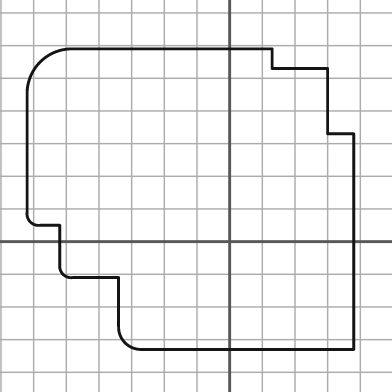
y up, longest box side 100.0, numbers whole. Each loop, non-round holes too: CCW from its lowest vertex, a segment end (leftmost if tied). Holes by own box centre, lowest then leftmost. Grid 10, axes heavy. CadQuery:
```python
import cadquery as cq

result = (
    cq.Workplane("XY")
    .moveTo(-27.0, -33.0)
    .lineTo(38.0, -33.0)
    .lineTo(38.0, 33.0)
    .lineTo(30.0, 33.0)
    .lineTo(30.0, 53.0)
    .lineTo(13.0, 53.0)
    .lineTo(13.0, 59.0)
    .lineTo(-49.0, 59.0)
    .threePointArc((-58.0, 55.0), (-62.0, 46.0))
    .lineTo(-62.0, 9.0)
    .threePointArc((-61.0, 6.0), (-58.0, 5.0))
    .lineTo(-52.0, 5.0)
    .lineTo(-52.0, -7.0)
    .threePointArc((-51.0, -10.0), (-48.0, -11.0))
    .lineTo(-34.0, -11.0)
    .lineTo(-34.0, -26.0)
    .threePointArc((-32.0, -31.0), (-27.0, -33.0))
    .close()
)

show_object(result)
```